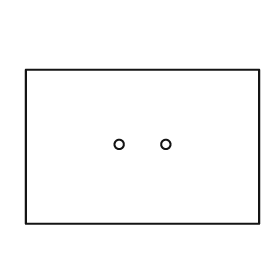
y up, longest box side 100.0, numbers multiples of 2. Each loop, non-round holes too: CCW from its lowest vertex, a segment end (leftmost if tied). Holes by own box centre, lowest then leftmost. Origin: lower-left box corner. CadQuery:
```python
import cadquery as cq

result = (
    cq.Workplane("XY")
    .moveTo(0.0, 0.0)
    .lineTo(100.0, 0.0)
    .lineTo(100.0, 66.0)
    .lineTo(0.0, 66.0)
    .close()
    .moveTo(40.0, 34.0)
    .circle(2.0)
    .moveTo(60.0, 34.0)
    .circle(2.0)
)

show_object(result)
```